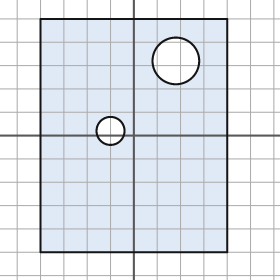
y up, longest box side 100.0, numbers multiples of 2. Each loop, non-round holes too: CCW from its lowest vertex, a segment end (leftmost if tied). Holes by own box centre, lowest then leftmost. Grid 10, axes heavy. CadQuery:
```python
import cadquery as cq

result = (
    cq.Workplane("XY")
    .moveTo(-40.0, -50.0)
    .lineTo(40.0, -50.0)
    .lineTo(40.0, 50.0)
    .lineTo(-40.0, 50.0)
    .close()
    .moveTo(-10.0, 2.0)
    .circle(6.0)
    .moveTo(18.0, 32.0)
    .circle(10.0)
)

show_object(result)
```